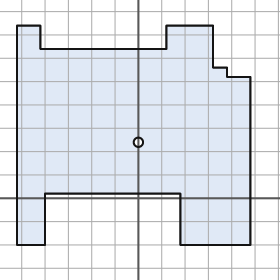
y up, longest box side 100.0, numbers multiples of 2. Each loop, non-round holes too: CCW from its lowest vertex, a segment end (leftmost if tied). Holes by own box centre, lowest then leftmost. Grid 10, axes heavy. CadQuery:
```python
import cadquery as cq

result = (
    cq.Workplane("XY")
    .moveTo(-52.0, -20.0)
    .lineTo(-40.0, -20.0)
    .lineTo(-40.0, 2.0)
    .lineTo(18.0, 2.0)
    .lineTo(18.0, -20.0)
    .lineTo(48.0, -20.0)
    .lineTo(48.0, 52.0)
    .lineTo(38.0, 52.0)
    .lineTo(38.0, 56.0)
    .lineTo(32.0, 56.0)
    .lineTo(32.0, 74.0)
    .lineTo(12.0, 74.0)
    .lineTo(12.0, 64.0)
    .lineTo(-42.0, 64.0)
    .lineTo(-42.0, 74.0)
    .lineTo(-52.0, 74.0)
    .close()
    .moveTo(0.0, 24.0)
    .circle(2.0)
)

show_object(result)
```